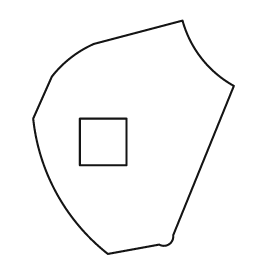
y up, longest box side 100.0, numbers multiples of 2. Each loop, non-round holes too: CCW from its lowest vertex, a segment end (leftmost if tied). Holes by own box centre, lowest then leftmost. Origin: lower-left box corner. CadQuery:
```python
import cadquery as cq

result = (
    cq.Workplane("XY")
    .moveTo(32.0, 0.0)
    .lineTo(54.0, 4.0)
    .threePointArc((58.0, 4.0), (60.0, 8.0))
    .lineTo(86.0, 72.0)
    .threePointArc((72.0, 84.0), (64.0, 100.0))
    .lineTo(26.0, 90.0)
    .threePointArc((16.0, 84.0), (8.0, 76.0))
    .lineTo(0.0, 58.0)
    .threePointArc((10.0, 26.0), (32.0, 0.0))
    .close()
    .moveTo(20.0, 38.0)
    .lineTo(40.0, 38.0)
    .lineTo(40.0, 58.0)
    .lineTo(20.0, 58.0)
    .close()
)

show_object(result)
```